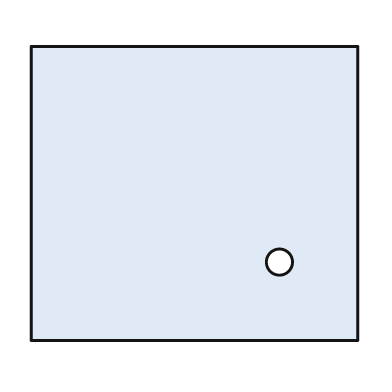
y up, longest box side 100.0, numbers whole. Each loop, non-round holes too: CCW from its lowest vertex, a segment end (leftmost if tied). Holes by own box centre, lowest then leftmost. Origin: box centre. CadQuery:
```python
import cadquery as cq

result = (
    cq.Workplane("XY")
    .moveTo(-50.0, -45.0)
    .lineTo(50.0, -45.0)
    .lineTo(50.0, 45.0)
    .lineTo(-50.0, 45.0)
    .close()
    .moveTo(26.0, -21.0)
    .circle(4.0)
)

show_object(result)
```